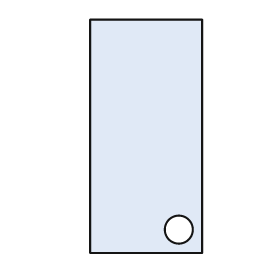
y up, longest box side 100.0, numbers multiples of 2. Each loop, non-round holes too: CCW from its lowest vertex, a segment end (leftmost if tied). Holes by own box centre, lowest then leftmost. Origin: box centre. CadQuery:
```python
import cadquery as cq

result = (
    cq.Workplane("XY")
    .moveTo(-24.0, -50.0)
    .lineTo(24.0, -50.0)
    .lineTo(24.0, 50.0)
    .lineTo(-24.0, 50.0)
    .close()
    .moveTo(14.0, -40.0)
    .circle(6.0)
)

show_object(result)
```